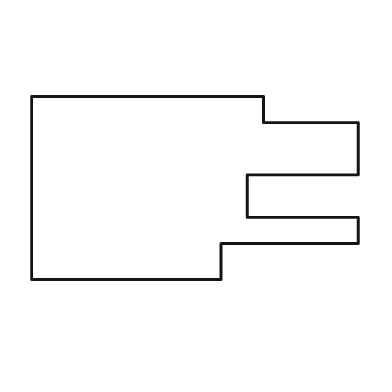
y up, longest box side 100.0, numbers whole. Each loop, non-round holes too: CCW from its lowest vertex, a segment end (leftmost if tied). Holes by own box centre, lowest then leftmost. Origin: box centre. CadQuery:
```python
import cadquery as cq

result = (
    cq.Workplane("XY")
    .moveTo(-50.0, -28.0)
    .lineTo(8.0, -28.0)
    .lineTo(8.0, -17.0)
    .lineTo(50.0, -17.0)
    .lineTo(50.0, -9.0)
    .lineTo(16.0, -9.0)
    .lineTo(16.0, 4.0)
    .lineTo(50.0, 4.0)
    .lineTo(50.0, 20.0)
    .lineTo(21.0, 20.0)
    .lineTo(21.0, 28.0)
    .lineTo(-50.0, 28.0)
    .close()
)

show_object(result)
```